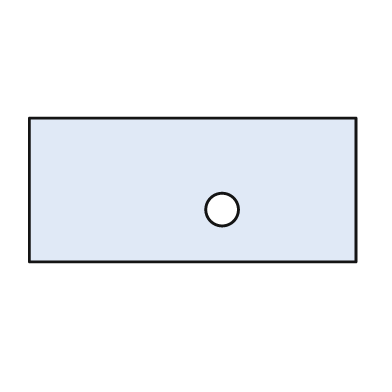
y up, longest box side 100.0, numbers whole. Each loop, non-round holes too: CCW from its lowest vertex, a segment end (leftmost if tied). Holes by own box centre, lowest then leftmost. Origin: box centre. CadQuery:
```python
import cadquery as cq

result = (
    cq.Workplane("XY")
    .moveTo(-50.0, -22.0)
    .lineTo(50.0, -22.0)
    .lineTo(50.0, 22.0)
    .lineTo(-50.0, 22.0)
    .close()
    .moveTo(9.0, -6.0)
    .circle(5.0)
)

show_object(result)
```